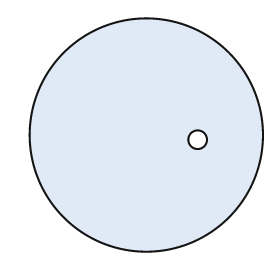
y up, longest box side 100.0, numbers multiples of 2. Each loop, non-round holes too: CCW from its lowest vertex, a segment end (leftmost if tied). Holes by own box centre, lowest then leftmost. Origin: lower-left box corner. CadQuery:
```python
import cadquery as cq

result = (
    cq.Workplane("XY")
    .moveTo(50.0, 50.0)
    .circle(50.0)
    .moveTo(72.0, 48.0)
    .circle(4.0)
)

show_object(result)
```